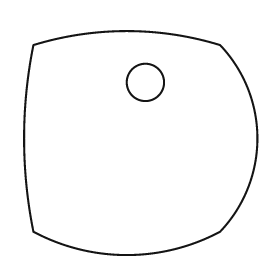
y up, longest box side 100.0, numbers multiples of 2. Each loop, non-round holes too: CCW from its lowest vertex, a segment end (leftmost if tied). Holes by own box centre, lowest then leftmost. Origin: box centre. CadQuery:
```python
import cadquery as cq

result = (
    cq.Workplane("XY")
    .moveTo(-46.0, -38.0)
    .threePointArc((-6.0, -48.0), (34.0, -38.0))
    .threePointArc((50.0, 2.0), (34.0, 42.0))
    .threePointArc((-6.0, 48.0), (-46.0, 42.0))
    .threePointArc((-50.0, 2.0), (-46.0, -38.0))
    .close()
    .moveTo(2.0, 26.0)
    .circle(8.0)
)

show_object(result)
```